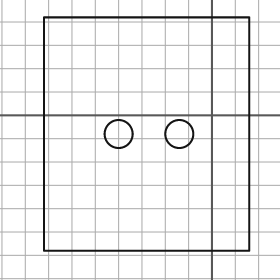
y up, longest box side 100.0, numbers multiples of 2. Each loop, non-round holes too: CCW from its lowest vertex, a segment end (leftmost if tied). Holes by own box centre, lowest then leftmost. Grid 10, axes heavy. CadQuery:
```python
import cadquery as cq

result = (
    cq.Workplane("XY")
    .moveTo(-72.0, -58.0)
    .lineTo(16.0, -58.0)
    .lineTo(16.0, 42.0)
    .lineTo(-72.0, 42.0)
    .close()
    .moveTo(-40.0, -8.0)
    .circle(6.0)
    .moveTo(-14.0, -8.0)
    .circle(6.0)
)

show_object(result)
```